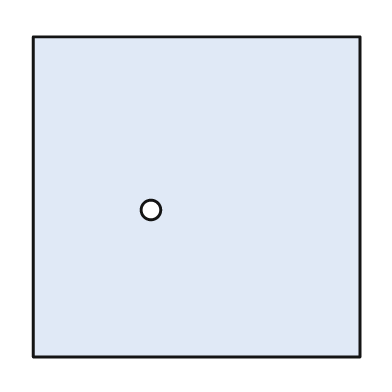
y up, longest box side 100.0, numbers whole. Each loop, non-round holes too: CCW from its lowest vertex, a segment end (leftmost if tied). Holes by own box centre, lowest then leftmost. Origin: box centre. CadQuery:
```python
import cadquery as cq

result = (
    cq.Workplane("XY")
    .moveTo(-50.0, -49.0)
    .lineTo(50.0, -49.0)
    .lineTo(50.0, 49.0)
    .lineTo(-50.0, 49.0)
    .close()
    .moveTo(-14.0, -4.0)
    .circle(3.0)
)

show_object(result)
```